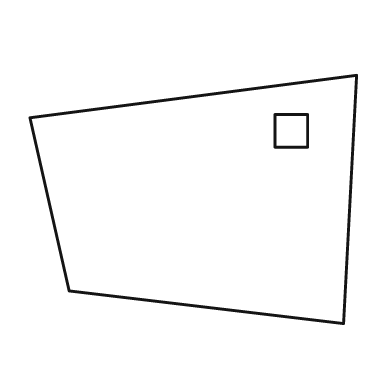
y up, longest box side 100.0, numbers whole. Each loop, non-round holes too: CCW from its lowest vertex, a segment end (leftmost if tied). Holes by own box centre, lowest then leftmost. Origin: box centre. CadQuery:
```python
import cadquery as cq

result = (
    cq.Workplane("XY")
    .moveTo(46.0, -38.0)
    .lineTo(50.0, 38.0)
    .lineTo(-50.0, 25.0)
    .lineTo(-38.0, -28.0)
    .close()
    .moveTo(25.0, 16.0)
    .lineTo(35.0, 16.0)
    .lineTo(35.0, 26.0)
    .lineTo(25.0, 26.0)
    .close()
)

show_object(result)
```